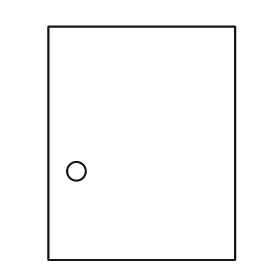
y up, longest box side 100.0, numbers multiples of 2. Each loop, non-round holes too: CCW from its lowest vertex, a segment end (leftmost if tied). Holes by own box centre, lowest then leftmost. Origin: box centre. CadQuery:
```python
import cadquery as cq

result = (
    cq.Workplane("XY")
    .moveTo(-40.0, -50.0)
    .lineTo(40.0, -50.0)
    .lineTo(40.0, 50.0)
    .lineTo(-40.0, 50.0)
    .close()
    .moveTo(-28.0, -12.0)
    .circle(4.0)
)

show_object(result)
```